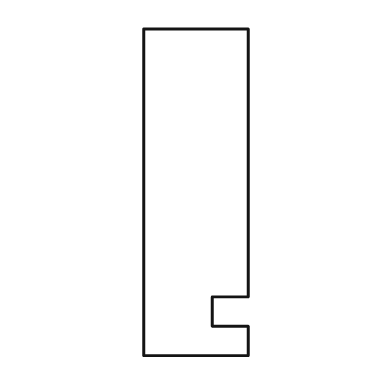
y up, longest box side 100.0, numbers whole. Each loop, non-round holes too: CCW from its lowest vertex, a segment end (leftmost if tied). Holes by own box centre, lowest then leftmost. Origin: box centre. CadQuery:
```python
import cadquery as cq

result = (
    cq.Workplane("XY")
    .moveTo(-16.0, -50.0)
    .lineTo(16.0, -50.0)
    .lineTo(16.0, -41.0)
    .lineTo(5.0, -41.0)
    .lineTo(5.0, -32.0)
    .lineTo(16.0, -32.0)
    .lineTo(16.0, 50.0)
    .lineTo(-16.0, 50.0)
    .close()
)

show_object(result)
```